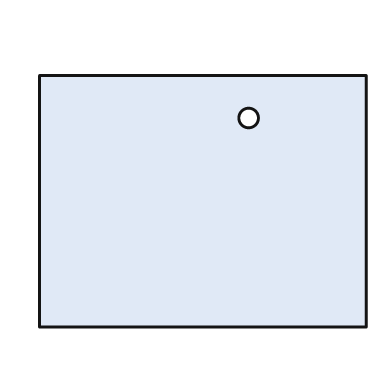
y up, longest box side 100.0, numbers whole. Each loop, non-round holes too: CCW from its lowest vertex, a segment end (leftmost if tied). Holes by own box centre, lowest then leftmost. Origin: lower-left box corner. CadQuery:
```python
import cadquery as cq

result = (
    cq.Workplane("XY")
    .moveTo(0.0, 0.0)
    .lineTo(100.0, 0.0)
    .lineTo(100.0, 77.0)
    .lineTo(0.0, 77.0)
    .close()
    .moveTo(64.0, 64.0)
    .circle(3.0)
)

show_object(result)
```